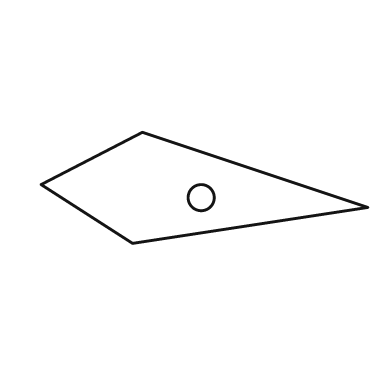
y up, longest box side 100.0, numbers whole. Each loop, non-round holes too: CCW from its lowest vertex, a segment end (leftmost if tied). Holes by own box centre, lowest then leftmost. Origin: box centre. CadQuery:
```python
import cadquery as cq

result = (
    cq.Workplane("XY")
    .moveTo(-22.0, -17.0)
    .lineTo(50.0, -6.0)
    .lineTo(-19.0, 17.0)
    .lineTo(-50.0, 1.0)
    .close()
    .moveTo(-1.0, -3.0)
    .circle(4.0)
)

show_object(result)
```